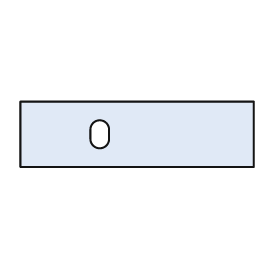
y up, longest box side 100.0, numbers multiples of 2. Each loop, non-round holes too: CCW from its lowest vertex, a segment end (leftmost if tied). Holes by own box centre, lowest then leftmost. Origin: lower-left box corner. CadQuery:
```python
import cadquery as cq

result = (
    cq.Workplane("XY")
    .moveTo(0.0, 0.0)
    .lineTo(100.0, 0.0)
    .lineTo(100.0, 28.0)
    .lineTo(0.0, 28.0)
    .close()
    .moveTo(30.0, 12.0)
    .threePointArc((34.0, 8.0), (38.0, 12.0))
    .lineTo(38.0, 16.0)
    .threePointArc((34.0, 20.0), (30.0, 16.0))
    .close()
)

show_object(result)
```